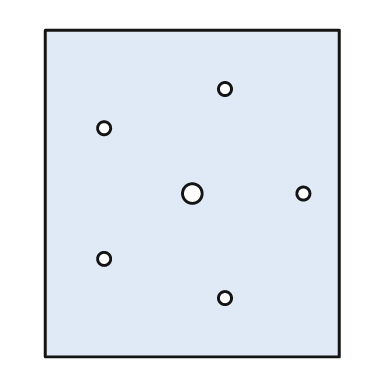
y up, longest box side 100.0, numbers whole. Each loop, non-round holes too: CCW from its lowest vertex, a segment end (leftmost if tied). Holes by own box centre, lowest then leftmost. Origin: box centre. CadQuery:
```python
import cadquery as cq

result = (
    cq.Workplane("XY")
    .moveTo(-45.0, -50.0)
    .lineTo(45.0, -50.0)
    .lineTo(45.0, 50.0)
    .lineTo(-45.0, 50.0)
    .close()
    .moveTo(10.0, -32.0)
    .circle(2.0)
    .moveTo(-27.0, -20.0)
    .circle(2.0)
    .moveTo(0.0, 0.0)
    .circle(3.0)
    .moveTo(34.0, 0.0)
    .circle(2.0)
    .moveTo(-27.0, 20.0)
    .circle(2.0)
    .moveTo(10.0, 32.0)
    .circle(2.0)
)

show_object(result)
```